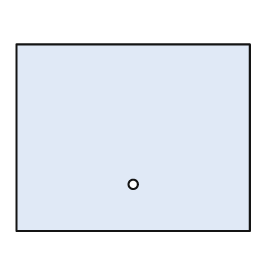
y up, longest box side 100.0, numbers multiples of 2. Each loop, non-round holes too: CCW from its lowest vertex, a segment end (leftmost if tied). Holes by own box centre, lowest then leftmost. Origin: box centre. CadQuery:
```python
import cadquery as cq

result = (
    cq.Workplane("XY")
    .moveTo(-50.0, -40.0)
    .lineTo(50.0, -40.0)
    .lineTo(50.0, 40.0)
    .lineTo(-50.0, 40.0)
    .close()
    .moveTo(0.0, -20.0)
    .circle(2.0)
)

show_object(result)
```